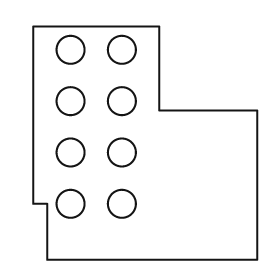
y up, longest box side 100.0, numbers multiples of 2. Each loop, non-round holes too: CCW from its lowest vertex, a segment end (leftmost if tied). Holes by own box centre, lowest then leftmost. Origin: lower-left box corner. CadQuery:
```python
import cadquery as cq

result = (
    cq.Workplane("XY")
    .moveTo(6.0, 0.0)
    .lineTo(96.0, 0.0)
    .lineTo(96.0, 64.0)
    .lineTo(54.0, 64.0)
    .lineTo(54.0, 100.0)
    .lineTo(0.0, 100.0)
    .lineTo(0.0, 24.0)
    .lineTo(6.0, 24.0)
    .close()
    .moveTo(16.0, 24.0)
    .circle(6.0)
    .moveTo(38.0, 24.0)
    .circle(6.0)
    .moveTo(16.0, 46.0)
    .circle(6.0)
    .moveTo(38.0, 46.0)
    .circle(6.0)
    .moveTo(16.0, 68.0)
    .circle(6.0)
    .moveTo(38.0, 68.0)
    .circle(6.0)
    .moveTo(16.0, 90.0)
    .circle(6.0)
    .moveTo(38.0, 90.0)
    .circle(6.0)
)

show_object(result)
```